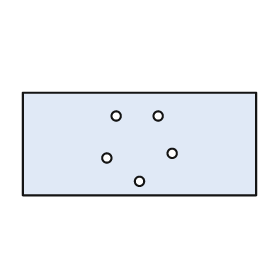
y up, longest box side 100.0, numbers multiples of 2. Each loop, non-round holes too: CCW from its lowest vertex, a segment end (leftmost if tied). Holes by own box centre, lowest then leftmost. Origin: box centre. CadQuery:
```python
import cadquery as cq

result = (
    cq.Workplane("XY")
    .moveTo(-50.0, -22.0)
    .lineTo(50.0, -22.0)
    .lineTo(50.0, 22.0)
    .lineTo(-50.0, 22.0)
    .close()
    .moveTo(0.0, -16.0)
    .circle(2.0)
    .moveTo(-14.0, -6.0)
    .circle(2.0)
    .moveTo(14.0, -4.0)
    .circle(2.0)
    .moveTo(-10.0, 12.0)
    .circle(2.0)
    .moveTo(8.0, 12.0)
    .circle(2.0)
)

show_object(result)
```